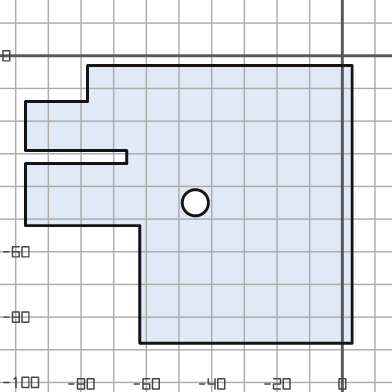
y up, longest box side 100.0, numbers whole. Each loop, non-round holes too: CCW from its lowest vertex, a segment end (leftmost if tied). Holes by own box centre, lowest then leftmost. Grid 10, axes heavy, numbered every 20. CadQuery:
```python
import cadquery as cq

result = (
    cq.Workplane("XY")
    .moveTo(-62.0, -88.0)
    .lineTo(3.0, -88.0)
    .lineTo(3.0, -3.0)
    .lineTo(-78.0, -3.0)
    .lineTo(-78.0, -14.0)
    .lineTo(-97.0, -14.0)
    .lineTo(-97.0, -29.0)
    .lineTo(-66.0, -29.0)
    .lineTo(-66.0, -33.0)
    .lineTo(-97.0, -33.0)
    .lineTo(-97.0, -52.0)
    .lineTo(-62.0, -52.0)
    .close()
    .moveTo(-45.0, -45.0)
    .circle(4.0)
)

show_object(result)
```